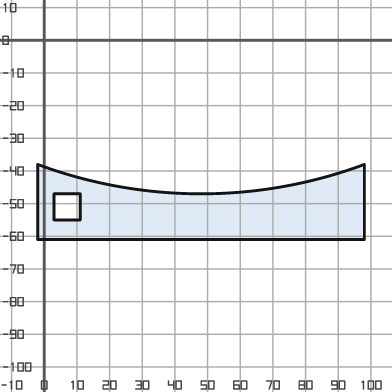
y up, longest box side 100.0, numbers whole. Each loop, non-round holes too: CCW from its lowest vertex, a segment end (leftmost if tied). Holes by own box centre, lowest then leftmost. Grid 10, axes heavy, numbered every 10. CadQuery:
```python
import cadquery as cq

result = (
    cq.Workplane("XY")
    .moveTo(-2.0, -61.0)
    .lineTo(98.0, -61.0)
    .lineTo(98.0, -38.0)
    .threePointArc((48.0, -47.0), (-2.0, -38.0))
    .close()
    .moveTo(3.0, -55.0)
    .lineTo(11.0, -55.0)
    .lineTo(11.0, -47.0)
    .lineTo(3.0, -47.0)
    .close()
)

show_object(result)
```